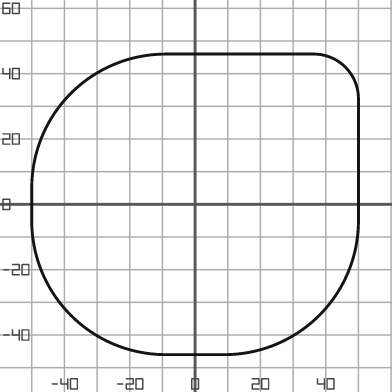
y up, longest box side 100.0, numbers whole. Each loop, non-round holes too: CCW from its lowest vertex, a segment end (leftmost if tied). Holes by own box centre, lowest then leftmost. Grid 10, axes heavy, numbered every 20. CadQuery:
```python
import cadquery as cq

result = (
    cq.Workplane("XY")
    .moveTo(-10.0, -46.0)
    .lineTo(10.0, -46.0)
    .threePointArc((38.0, -34.0), (50.0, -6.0))
    .lineTo(50.0, 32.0)
    .threePointArc((46.0, 42.0), (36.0, 46.0))
    .lineTo(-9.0, 46.0)
    .threePointArc((-38.0, 34.0), (-50.0, 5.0))
    .lineTo(-50.0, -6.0)
    .threePointArc((-38.0, -34.0), (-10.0, -46.0))
    .close()
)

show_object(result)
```